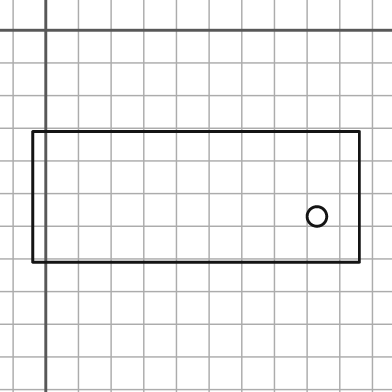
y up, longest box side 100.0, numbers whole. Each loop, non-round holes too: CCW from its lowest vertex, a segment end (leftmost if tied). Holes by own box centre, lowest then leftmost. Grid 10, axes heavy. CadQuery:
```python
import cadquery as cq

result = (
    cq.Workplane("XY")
    .moveTo(-4.0, -71.0)
    .lineTo(96.0, -71.0)
    .lineTo(96.0, -31.0)
    .lineTo(-4.0, -31.0)
    .close()
    .moveTo(83.0, -57.0)
    .circle(3.0)
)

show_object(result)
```